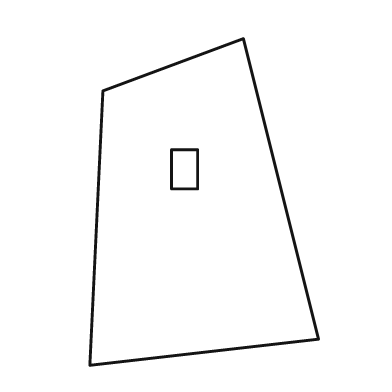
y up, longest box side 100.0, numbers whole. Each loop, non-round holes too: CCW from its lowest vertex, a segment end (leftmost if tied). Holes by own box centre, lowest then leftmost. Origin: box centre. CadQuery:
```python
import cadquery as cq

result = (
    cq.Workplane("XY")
    .moveTo(-35.0, -50.0)
    .lineTo(35.0, -42.0)
    .lineTo(12.0, 50.0)
    .lineTo(-31.0, 34.0)
    .close()
    .moveTo(-10.0, 4.0)
    .lineTo(-2.0, 4.0)
    .lineTo(-2.0, 16.0)
    .lineTo(-10.0, 16.0)
    .close()
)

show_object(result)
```